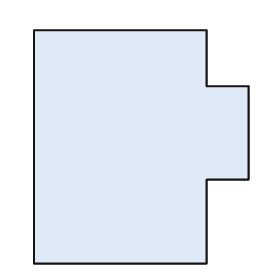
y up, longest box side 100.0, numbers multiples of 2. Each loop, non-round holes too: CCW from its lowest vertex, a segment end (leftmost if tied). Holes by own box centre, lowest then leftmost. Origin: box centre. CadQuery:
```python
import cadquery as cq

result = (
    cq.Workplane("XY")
    .moveTo(-46.0, -50.0)
    .lineTo(28.0, -50.0)
    .lineTo(28.0, -14.0)
    .lineTo(46.0, -14.0)
    .lineTo(46.0, 26.0)
    .lineTo(28.0, 26.0)
    .lineTo(28.0, 50.0)
    .lineTo(-46.0, 50.0)
    .close()
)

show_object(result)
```